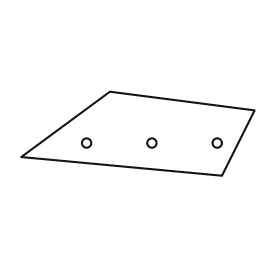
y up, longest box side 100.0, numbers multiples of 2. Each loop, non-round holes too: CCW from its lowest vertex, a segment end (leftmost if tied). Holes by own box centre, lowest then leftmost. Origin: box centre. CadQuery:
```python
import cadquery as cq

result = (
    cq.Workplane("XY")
    .moveTo(36.0, -18.0)
    .lineTo(50.0, 10.0)
    .lineTo(-12.0, 18.0)
    .lineTo(-50.0, -10.0)
    .close()
    .moveTo(-22.0, -4.0)
    .circle(2.0)
    .moveTo(6.0, -4.0)
    .circle(2.0)
    .moveTo(34.0, -4.0)
    .circle(2.0)
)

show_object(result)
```